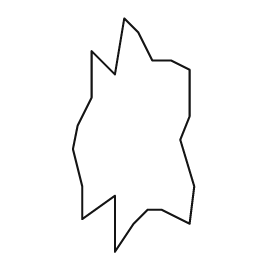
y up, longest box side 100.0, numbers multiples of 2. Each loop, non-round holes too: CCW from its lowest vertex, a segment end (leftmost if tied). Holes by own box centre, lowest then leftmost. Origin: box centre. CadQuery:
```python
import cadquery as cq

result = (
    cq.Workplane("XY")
    .moveTo(-8.0, -50.0)
    .lineTo(0.0, -38.0)
    .lineTo(6.0, -32.0)
    .lineTo(12.0, -32.0)
    .lineTo(24.0, -38.0)
    .lineTo(26.0, -22.0)
    .lineTo(20.0, -2.0)
    .lineTo(24.0, 8.0)
    .lineTo(24.0, 28.0)
    .lineTo(16.0, 32.0)
    .lineTo(8.0, 32.0)
    .lineTo(2.0, 44.0)
    .lineTo(-4.0, 50.0)
    .lineTo(-8.0, 26.0)
    .lineTo(-18.0, 36.0)
    .lineTo(-18.0, 16.0)
    .lineTo(-24.0, 4.0)
    .lineTo(-26.0, -6.0)
    .lineTo(-22.0, -22.0)
    .lineTo(-22.0, -36.0)
    .lineTo(-8.0, -26.0)
    .close()
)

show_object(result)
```